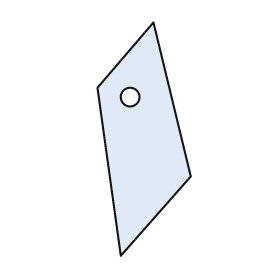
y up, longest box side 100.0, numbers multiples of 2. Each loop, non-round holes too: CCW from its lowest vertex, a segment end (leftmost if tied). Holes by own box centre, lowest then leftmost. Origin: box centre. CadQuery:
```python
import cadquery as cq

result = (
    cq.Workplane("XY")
    .moveTo(-10.0, -50.0)
    .lineTo(20.0, -16.0)
    .lineTo(4.0, 50.0)
    .lineTo(-20.0, 22.0)
    .close()
    .moveTo(-6.0, 18.0)
    .circle(4.0)
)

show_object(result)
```